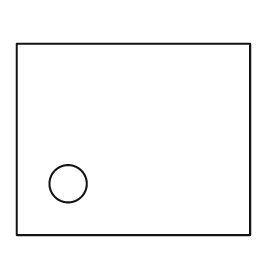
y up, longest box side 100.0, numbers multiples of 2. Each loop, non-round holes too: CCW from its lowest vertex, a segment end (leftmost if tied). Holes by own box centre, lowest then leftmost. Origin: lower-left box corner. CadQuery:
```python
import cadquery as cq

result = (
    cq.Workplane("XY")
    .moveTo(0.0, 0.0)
    .lineTo(100.0, 0.0)
    .lineTo(100.0, 82.0)
    .lineTo(0.0, 82.0)
    .close()
    .moveTo(22.0, 22.0)
    .circle(8.0)
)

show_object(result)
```